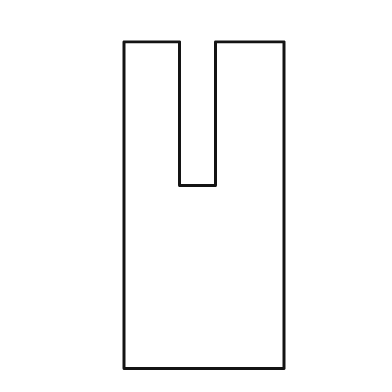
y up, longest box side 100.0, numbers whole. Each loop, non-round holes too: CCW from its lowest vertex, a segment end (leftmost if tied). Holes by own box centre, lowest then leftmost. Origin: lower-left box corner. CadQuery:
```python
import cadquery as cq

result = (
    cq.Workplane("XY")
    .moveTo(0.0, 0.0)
    .lineTo(49.0, 0.0)
    .lineTo(49.0, 100.0)
    .lineTo(28.0, 100.0)
    .lineTo(28.0, 56.0)
    .lineTo(17.0, 56.0)
    .lineTo(17.0, 100.0)
    .lineTo(0.0, 100.0)
    .close()
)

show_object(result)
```